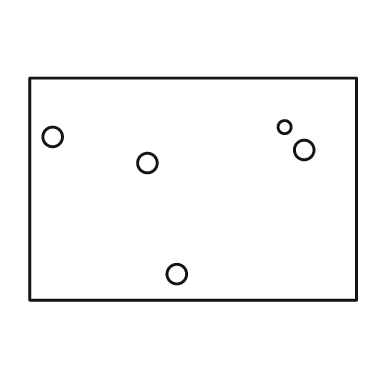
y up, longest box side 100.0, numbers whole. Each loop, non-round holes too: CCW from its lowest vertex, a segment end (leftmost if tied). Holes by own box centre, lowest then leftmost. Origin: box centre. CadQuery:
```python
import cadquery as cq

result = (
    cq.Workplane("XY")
    .moveTo(-50.0, -34.0)
    .lineTo(50.0, -34.0)
    .lineTo(50.0, 34.0)
    .lineTo(-50.0, 34.0)
    .close()
    .moveTo(-5.0, -26.0)
    .circle(3.0)
    .moveTo(-14.0, 8.0)
    .circle(3.0)
    .moveTo(34.0, 12.0)
    .circle(3.0)
    .moveTo(-43.0, 16.0)
    .circle(3.0)
    .moveTo(28.0, 19.0)
    .circle(2.0)
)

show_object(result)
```